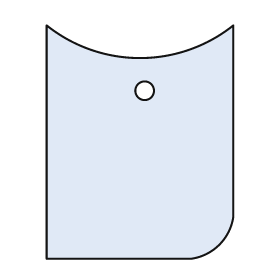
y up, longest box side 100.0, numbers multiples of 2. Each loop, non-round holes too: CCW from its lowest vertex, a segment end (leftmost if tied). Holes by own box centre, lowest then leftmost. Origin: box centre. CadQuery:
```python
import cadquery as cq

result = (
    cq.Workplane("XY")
    .moveTo(-40.0, -50.0)
    .lineTo(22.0, -50.0)
    .threePointArc((34.0, -44.0), (40.0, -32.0))
    .lineTo(40.0, 50.0)
    .threePointArc((0.0, 36.0), (-40.0, 50.0))
    .close()
    .moveTo(2.0, 22.0)
    .circle(4.0)
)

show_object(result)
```